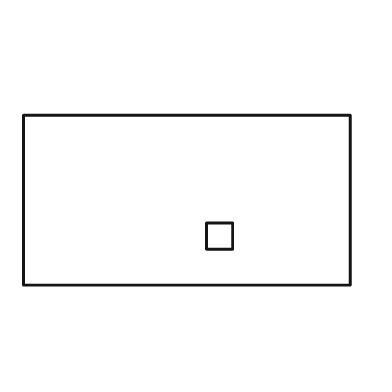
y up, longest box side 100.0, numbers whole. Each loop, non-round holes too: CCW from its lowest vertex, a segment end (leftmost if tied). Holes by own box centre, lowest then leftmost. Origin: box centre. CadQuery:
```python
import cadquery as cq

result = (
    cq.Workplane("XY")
    .moveTo(-50.0, -26.0)
    .lineTo(50.0, -26.0)
    .lineTo(50.0, 26.0)
    .lineTo(-50.0, 26.0)
    .close()
    .moveTo(6.0, -15.0)
    .lineTo(14.0, -15.0)
    .lineTo(14.0, -7.0)
    .lineTo(6.0, -7.0)
    .close()
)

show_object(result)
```